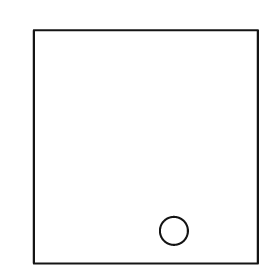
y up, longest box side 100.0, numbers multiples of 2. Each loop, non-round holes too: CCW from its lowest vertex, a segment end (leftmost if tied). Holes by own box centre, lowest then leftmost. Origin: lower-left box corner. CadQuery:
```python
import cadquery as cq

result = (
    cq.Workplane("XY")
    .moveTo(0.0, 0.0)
    .lineTo(96.0, 0.0)
    .lineTo(96.0, 100.0)
    .lineTo(0.0, 100.0)
    .close()
    .moveTo(60.0, 14.0)
    .circle(6.0)
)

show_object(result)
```